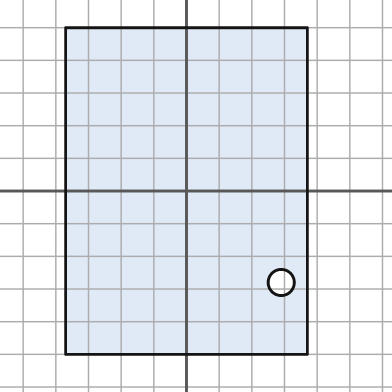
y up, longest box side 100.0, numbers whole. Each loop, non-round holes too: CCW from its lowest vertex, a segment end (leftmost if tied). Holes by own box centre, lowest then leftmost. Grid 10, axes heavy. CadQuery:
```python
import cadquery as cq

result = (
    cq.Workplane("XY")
    .moveTo(-37.0, -50.0)
    .lineTo(37.0, -50.0)
    .lineTo(37.0, 50.0)
    .lineTo(-37.0, 50.0)
    .close()
    .moveTo(29.0, -28.0)
    .circle(4.0)
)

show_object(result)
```